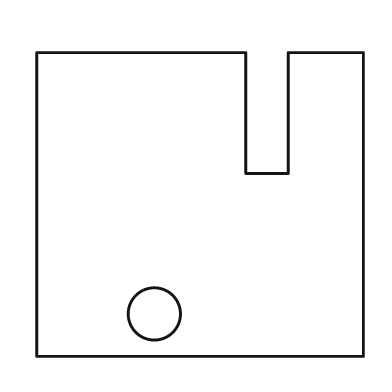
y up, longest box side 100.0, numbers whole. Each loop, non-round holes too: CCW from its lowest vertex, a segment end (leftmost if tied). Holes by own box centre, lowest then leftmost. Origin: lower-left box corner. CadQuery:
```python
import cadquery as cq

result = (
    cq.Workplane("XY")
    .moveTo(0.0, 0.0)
    .lineTo(100.0, 0.0)
    .lineTo(100.0, 93.0)
    .lineTo(77.0, 93.0)
    .lineTo(77.0, 56.0)
    .lineTo(64.0, 56.0)
    .lineTo(64.0, 93.0)
    .lineTo(0.0, 93.0)
    .close()
    .moveTo(36.0, 13.0)
    .circle(8.0)
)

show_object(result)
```